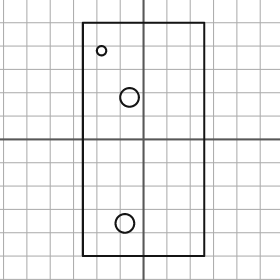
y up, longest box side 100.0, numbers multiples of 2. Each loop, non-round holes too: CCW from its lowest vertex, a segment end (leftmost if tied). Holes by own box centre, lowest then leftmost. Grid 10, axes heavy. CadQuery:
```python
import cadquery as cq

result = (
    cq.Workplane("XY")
    .moveTo(-26.0, -50.0)
    .lineTo(26.0, -50.0)
    .lineTo(26.0, 50.0)
    .lineTo(-26.0, 50.0)
    .close()
    .moveTo(-8.0, -36.0)
    .circle(4.0)
    .moveTo(-6.0, 18.0)
    .circle(4.0)
    .moveTo(-18.0, 38.0)
    .circle(2.0)
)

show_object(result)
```